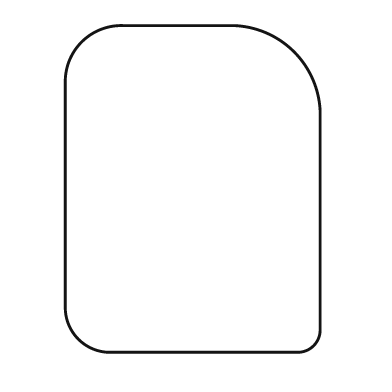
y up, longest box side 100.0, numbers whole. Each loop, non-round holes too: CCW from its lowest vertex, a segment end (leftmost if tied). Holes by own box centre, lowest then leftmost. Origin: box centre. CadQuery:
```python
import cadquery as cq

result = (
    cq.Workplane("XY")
    .moveTo(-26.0, -50.0)
    .lineTo(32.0, -50.0)
    .threePointArc((37.0, -48.0), (39.0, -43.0))
    .lineTo(39.0, 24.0)
    .threePointArc((31.0, 42.0), (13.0, 50.0))
    .lineTo(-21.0, 50.0)
    .threePointArc((-34.0, 45.0), (-39.0, 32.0))
    .lineTo(-39.0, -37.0)
    .threePointArc((-35.0, -46.0), (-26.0, -50.0))
    .close()
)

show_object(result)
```